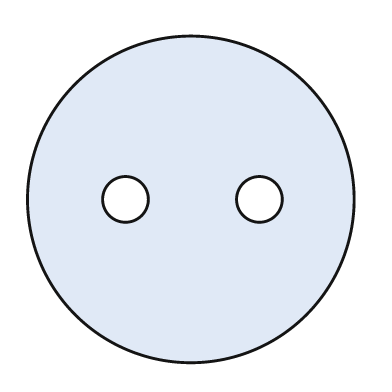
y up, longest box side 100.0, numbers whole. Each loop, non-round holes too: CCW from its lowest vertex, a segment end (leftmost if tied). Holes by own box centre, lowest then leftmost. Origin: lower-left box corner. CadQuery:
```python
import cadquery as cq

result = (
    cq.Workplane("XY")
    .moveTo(50.0, 50.0)
    .circle(50.0)
    .moveTo(30.0, 50.0)
    .circle(7.0)
    .moveTo(71.0, 50.0)
    .circle(7.0)
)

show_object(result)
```